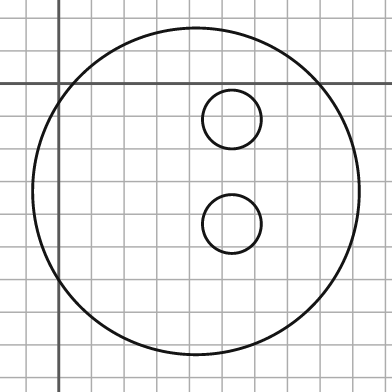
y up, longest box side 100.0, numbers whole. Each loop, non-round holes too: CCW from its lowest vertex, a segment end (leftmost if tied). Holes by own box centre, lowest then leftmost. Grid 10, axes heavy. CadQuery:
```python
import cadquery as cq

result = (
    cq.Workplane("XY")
    .moveTo(42.0, -33.0)
    .circle(50.0)
    .moveTo(53.0, -43.0)
    .circle(9.0)
    .moveTo(53.0, -11.0)
    .circle(9.0)
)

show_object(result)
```